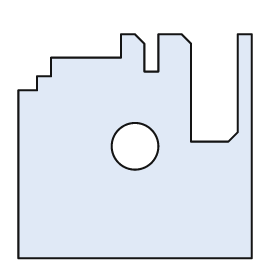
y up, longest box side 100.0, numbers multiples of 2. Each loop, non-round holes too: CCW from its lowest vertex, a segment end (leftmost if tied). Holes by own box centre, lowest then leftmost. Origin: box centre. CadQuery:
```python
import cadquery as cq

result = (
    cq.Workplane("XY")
    .moveTo(-50.0, -48.0)
    .lineTo(50.0, -48.0)
    .lineTo(50.0, 48.0)
    .lineTo(44.0, 48.0)
    .lineTo(44.0, 6.0)
    .lineTo(40.0, 2.0)
    .lineTo(24.0, 2.0)
    .lineTo(24.0, 44.0)
    .lineTo(20.0, 48.0)
    .lineTo(10.0, 48.0)
    .lineTo(10.0, 32.0)
    .lineTo(4.0, 32.0)
    .lineTo(4.0, 44.0)
    .lineTo(0.0, 48.0)
    .lineTo(-6.0, 48.0)
    .lineTo(-6.0, 38.0)
    .lineTo(-36.0, 38.0)
    .lineTo(-36.0, 30.0)
    .lineTo(-42.0, 30.0)
    .lineTo(-42.0, 24.0)
    .lineTo(-50.0, 24.0)
    .close()
    .moveTo(0.0, 0.0)
    .circle(10.0)
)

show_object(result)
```